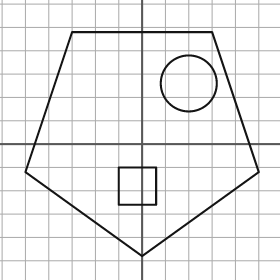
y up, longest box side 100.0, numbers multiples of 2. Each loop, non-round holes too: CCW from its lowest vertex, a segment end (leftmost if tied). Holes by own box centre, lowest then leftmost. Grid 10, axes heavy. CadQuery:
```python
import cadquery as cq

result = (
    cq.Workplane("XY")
    .moveTo(0.0, -48.0)
    .lineTo(50.0, -12.0)
    .lineTo(30.0, 48.0)
    .lineTo(-30.0, 48.0)
    .lineTo(-50.0, -12.0)
    .close()
    .moveTo(-10.0, -26.0)
    .lineTo(6.0, -26.0)
    .lineTo(6.0, -10.0)
    .lineTo(-10.0, -10.0)
    .close()
    .moveTo(20.0, 26.0)
    .circle(12.0)
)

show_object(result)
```